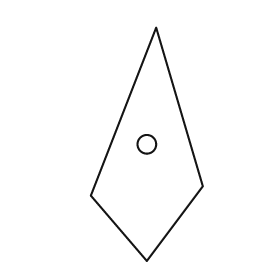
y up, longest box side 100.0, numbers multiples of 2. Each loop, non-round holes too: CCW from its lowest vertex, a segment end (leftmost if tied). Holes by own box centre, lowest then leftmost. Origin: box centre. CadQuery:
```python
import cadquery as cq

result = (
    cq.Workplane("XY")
    .moveTo(0.0, -50.0)
    .lineTo(24.0, -18.0)
    .lineTo(4.0, 50.0)
    .lineTo(-24.0, -22.0)
    .close()
    .moveTo(0.0, 0.0)
    .circle(4.0)
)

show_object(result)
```